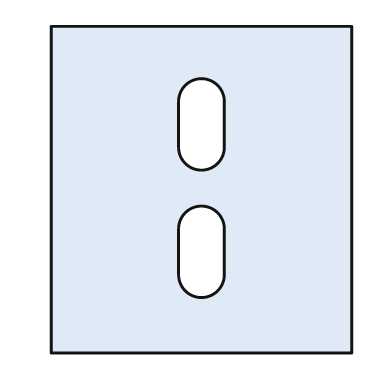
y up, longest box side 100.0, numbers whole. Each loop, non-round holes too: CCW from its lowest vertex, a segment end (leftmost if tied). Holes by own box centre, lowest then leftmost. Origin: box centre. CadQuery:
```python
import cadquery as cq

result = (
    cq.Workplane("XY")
    .moveTo(-46.0, -50.0)
    .lineTo(46.0, -50.0)
    .lineTo(46.0, 50.0)
    .lineTo(-46.0, 50.0)
    .close()
    .moveTo(-7.0, -26.0)
    .threePointArc((0.0, -33.0), (7.0, -26.0))
    .lineTo(7.0, -12.0)
    .threePointArc((0.0, -5.0), (-7.0, -12.0))
    .close()
    .moveTo(-7.0, 13.0)
    .threePointArc((0.0, 6.0), (7.0, 13.0))
    .lineTo(7.0, 27.0)
    .threePointArc((0.0, 34.0), (-7.0, 27.0))
    .close()
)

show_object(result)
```